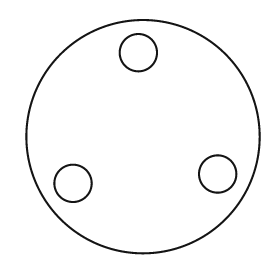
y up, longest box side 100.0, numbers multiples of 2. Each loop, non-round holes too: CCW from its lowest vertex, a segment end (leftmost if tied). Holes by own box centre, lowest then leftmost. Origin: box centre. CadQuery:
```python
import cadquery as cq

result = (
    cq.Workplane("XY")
    .moveTo(0.0, 0.0)
    .circle(50.0)
    .moveTo(-30.0, -20.0)
    .circle(8.0)
    .moveTo(32.0, -16.0)
    .circle(8.0)
    .moveTo(-2.0, 36.0)
    .circle(8.0)
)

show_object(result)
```